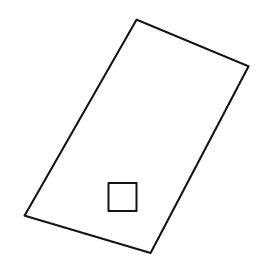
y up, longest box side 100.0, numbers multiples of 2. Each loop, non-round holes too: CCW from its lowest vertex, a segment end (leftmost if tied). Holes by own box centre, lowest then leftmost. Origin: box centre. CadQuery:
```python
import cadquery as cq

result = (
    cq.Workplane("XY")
    .moveTo(6.0, -50.0)
    .lineTo(48.0, 30.0)
    .lineTo(0.0, 50.0)
    .lineTo(-48.0, -34.0)
    .close()
    .moveTo(-12.0, -32.0)
    .lineTo(0.0, -32.0)
    .lineTo(0.0, -20.0)
    .lineTo(-12.0, -20.0)
    .close()
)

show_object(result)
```